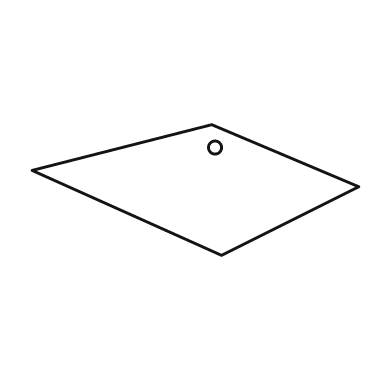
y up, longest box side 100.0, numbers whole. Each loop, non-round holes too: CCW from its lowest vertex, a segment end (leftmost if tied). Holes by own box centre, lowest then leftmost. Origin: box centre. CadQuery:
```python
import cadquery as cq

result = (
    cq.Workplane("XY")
    .moveTo(8.0, -20.0)
    .lineTo(50.0, 1.0)
    .lineTo(5.0, 20.0)
    .lineTo(-50.0, 6.0)
    .close()
    .moveTo(6.0, 13.0)
    .circle(2.0)
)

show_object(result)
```